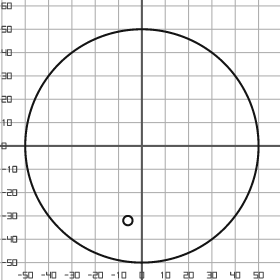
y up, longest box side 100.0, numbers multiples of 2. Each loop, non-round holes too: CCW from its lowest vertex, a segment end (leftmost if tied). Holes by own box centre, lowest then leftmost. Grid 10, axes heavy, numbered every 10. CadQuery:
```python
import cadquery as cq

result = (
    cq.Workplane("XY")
    .moveTo(0.0, 0.0)
    .circle(50.0)
    .moveTo(-6.0, -32.0)
    .circle(2.0)
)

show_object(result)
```